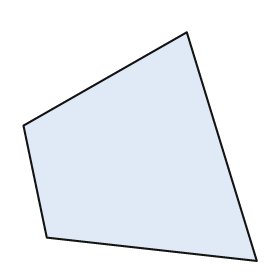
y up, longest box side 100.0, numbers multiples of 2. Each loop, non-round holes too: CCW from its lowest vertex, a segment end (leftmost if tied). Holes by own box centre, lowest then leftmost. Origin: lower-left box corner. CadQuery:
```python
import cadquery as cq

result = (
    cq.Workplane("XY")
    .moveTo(100.0, 0.0)
    .lineTo(70.0, 98.0)
    .lineTo(0.0, 58.0)
    .lineTo(10.0, 10.0)
    .close()
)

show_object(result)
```